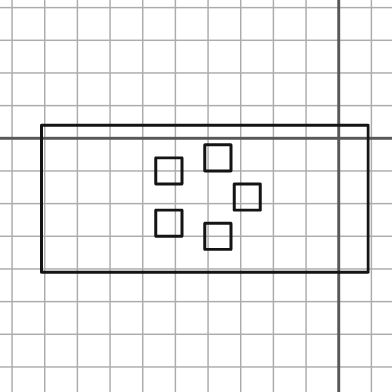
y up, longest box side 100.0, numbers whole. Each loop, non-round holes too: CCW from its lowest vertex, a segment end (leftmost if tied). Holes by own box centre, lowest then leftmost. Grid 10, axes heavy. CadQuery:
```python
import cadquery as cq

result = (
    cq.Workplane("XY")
    .moveTo(-91.0, -41.0)
    .lineTo(9.0, -41.0)
    .lineTo(9.0, 4.0)
    .lineTo(-91.0, 4.0)
    .close()
    .moveTo(-41.0, -34.0)
    .lineTo(-33.0, -34.0)
    .lineTo(-33.0, -26.0)
    .lineTo(-41.0, -26.0)
    .close()
    .moveTo(-56.0, -30.0)
    .lineTo(-48.0, -30.0)
    .lineTo(-48.0, -22.0)
    .lineTo(-56.0, -22.0)
    .close()
    .moveTo(-32.0, -22.0)
    .lineTo(-24.0, -22.0)
    .lineTo(-24.0, -14.0)
    .lineTo(-32.0, -14.0)
    .close()
    .moveTo(-56.0, -14.0)
    .lineTo(-48.0, -14.0)
    .lineTo(-48.0, -6.0)
    .lineTo(-56.0, -6.0)
    .close()
    .moveTo(-41.0, -10.0)
    .lineTo(-33.0, -10.0)
    .lineTo(-33.0, -2.0)
    .lineTo(-41.0, -2.0)
    .close()
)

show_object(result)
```